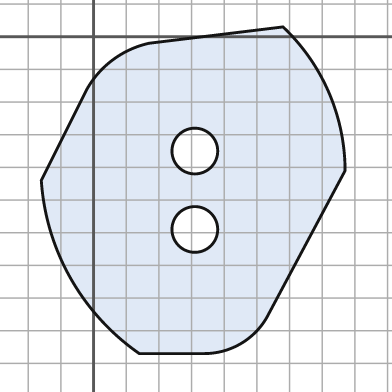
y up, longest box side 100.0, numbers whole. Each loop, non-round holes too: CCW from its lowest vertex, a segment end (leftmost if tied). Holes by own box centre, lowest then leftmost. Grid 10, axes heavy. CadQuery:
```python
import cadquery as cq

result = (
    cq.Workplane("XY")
    .moveTo(14.0, -97.0)
    .lineTo(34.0, -97.0)
    .threePointArc((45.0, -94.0), (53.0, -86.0))
    .lineTo(77.0, -41.0)
    .threePointArc((72.0, -17.0), (58.0, 3.0))
    .lineTo(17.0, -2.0)
    .threePointArc((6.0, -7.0), (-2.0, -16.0))
    .lineTo(-16.0, -44.0)
    .threePointArc((-7.0, -74.0), (14.0, -97.0))
    .close()
    .moveTo(31.0, -59.0)
    .circle(7.0)
    .moveTo(31.0, -35.0)
    .circle(7.0)
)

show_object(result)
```